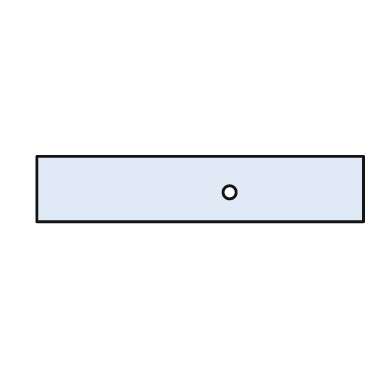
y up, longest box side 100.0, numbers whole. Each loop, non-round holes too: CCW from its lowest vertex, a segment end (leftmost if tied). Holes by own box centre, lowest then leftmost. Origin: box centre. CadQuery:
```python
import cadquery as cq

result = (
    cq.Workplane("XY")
    .moveTo(-50.0, -10.0)
    .lineTo(50.0, -10.0)
    .lineTo(50.0, 10.0)
    .lineTo(-50.0, 10.0)
    .close()
    .moveTo(9.0, -1.0)
    .circle(2.0)
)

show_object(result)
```